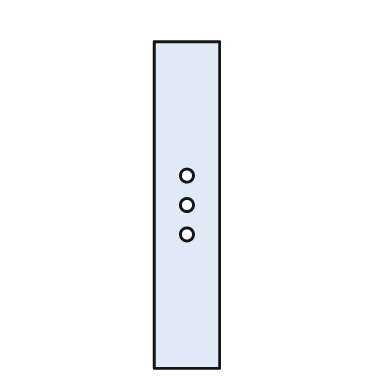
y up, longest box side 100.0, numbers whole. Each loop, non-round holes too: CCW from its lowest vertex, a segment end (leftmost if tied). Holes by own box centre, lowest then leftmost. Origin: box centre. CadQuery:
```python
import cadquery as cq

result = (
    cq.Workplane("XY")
    .moveTo(-10.0, -50.0)
    .lineTo(10.0, -50.0)
    .lineTo(10.0, 50.0)
    .lineTo(-10.0, 50.0)
    .close()
    .moveTo(0.0, -9.0)
    .circle(2.0)
    .moveTo(0.0, 0.0)
    .circle(2.0)
    .moveTo(0.0, 9.0)
    .circle(2.0)
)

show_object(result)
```